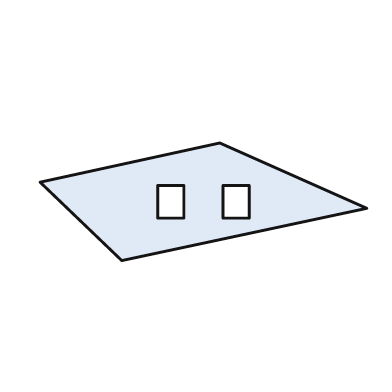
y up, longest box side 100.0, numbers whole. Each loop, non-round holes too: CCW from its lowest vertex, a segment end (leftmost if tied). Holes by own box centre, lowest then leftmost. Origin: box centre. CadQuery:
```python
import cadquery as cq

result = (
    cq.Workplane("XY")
    .moveTo(-25.0, -18.0)
    .lineTo(50.0, -2.0)
    .lineTo(5.0, 18.0)
    .lineTo(-50.0, 6.0)
    .close()
    .moveTo(-14.0, -5.0)
    .lineTo(-6.0, -5.0)
    .lineTo(-6.0, 5.0)
    .lineTo(-14.0, 5.0)
    .close()
    .moveTo(6.0, -5.0)
    .lineTo(14.0, -5.0)
    .lineTo(14.0, 5.0)
    .lineTo(6.0, 5.0)
    .close()
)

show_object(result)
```